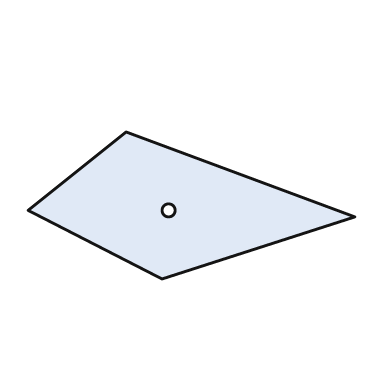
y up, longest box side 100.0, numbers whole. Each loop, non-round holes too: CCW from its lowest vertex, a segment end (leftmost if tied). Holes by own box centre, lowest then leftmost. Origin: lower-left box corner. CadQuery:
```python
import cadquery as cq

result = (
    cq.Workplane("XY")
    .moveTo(41.0, 0.0)
    .lineTo(100.0, 19.0)
    .lineTo(30.0, 45.0)
    .lineTo(0.0, 21.0)
    .close()
    .moveTo(43.0, 21.0)
    .circle(2.0)
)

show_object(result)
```